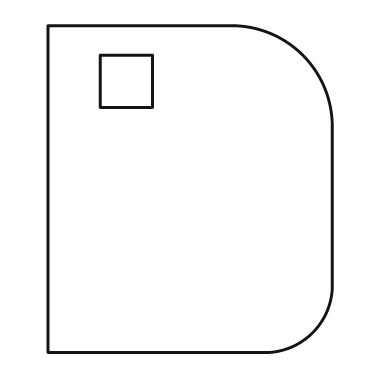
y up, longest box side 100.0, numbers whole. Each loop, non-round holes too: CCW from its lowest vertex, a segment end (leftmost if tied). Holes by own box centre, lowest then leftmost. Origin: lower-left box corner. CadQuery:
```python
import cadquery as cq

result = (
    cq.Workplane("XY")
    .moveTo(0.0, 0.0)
    .lineTo(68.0, 0.0)
    .threePointArc((81.0, 6.0), (87.0, 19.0))
    .lineTo(87.0, 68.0)
    .threePointArc((78.0, 91.0), (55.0, 100.0))
    .lineTo(0.0, 100.0)
    .close()
    .moveTo(16.0, 75.0)
    .lineTo(32.0, 75.0)
    .lineTo(32.0, 91.0)
    .lineTo(16.0, 91.0)
    .close()
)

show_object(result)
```